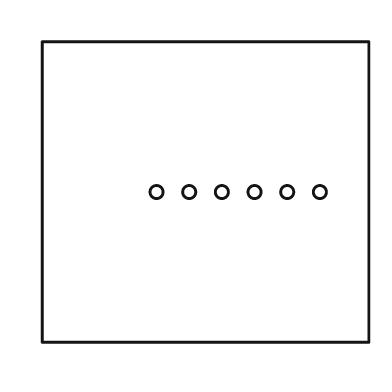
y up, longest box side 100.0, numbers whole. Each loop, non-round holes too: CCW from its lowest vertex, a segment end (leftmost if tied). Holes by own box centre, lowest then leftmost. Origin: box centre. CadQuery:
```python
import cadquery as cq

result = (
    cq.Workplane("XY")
    .moveTo(-50.0, -46.0)
    .lineTo(50.0, -46.0)
    .lineTo(50.0, 46.0)
    .lineTo(-50.0, 46.0)
    .close()
    .moveTo(-15.0, 0.0)
    .circle(2.0)
    .moveTo(-5.0, 0.0)
    .circle(2.0)
    .moveTo(5.0, 0.0)
    .circle(2.0)
    .moveTo(15.0, 0.0)
    .circle(2.0)
    .moveTo(25.0, 0.0)
    .circle(2.0)
    .moveTo(35.0, 0.0)
    .circle(2.0)
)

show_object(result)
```